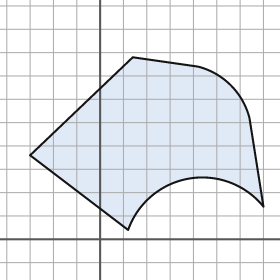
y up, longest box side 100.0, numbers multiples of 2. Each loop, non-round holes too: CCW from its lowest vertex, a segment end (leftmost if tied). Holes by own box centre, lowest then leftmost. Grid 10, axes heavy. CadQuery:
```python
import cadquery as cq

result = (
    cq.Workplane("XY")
    .moveTo(12.0, 4.0)
    .threePointArc((38.0, 26.0), (70.0, 14.0))
    .lineTo(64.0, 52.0)
    .threePointArc((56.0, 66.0), (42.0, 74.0))
    .lineTo(14.0, 78.0)
    .lineTo(-30.0, 36.0)
    .close()
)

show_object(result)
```